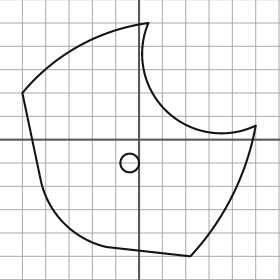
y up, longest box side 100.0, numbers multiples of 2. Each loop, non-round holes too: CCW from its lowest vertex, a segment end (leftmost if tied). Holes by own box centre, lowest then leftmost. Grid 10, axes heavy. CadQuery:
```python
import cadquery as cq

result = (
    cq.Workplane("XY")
    .moveTo(22.0, -50.0)
    .threePointArc((40.0, -24.0), (50.0, 6.0))
    .threePointArc((12.0, 12.0), (4.0, 50.0))
    .threePointArc((-26.0, 40.0), (-50.0, 20.0))
    .lineTo(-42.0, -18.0)
    .threePointArc((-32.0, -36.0), (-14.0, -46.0))
    .close()
    .moveTo(-4.0, -10.0)
    .circle(4.0)
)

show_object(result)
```